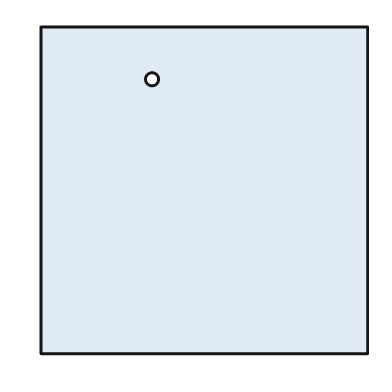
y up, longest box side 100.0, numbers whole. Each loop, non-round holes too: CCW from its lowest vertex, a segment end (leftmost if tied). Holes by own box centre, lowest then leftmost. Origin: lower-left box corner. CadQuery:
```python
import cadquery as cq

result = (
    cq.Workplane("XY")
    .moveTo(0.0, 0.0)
    .lineTo(100.0, 0.0)
    .lineTo(100.0, 100.0)
    .lineTo(0.0, 100.0)
    .close()
    .moveTo(34.0, 84.0)
    .circle(2.0)
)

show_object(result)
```